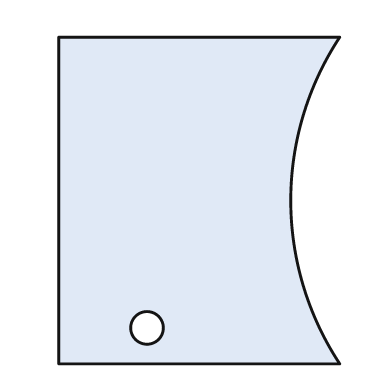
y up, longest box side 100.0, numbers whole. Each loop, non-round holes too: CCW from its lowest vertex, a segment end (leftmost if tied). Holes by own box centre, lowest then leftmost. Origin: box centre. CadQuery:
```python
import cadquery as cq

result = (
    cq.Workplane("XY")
    .moveTo(-43.0, -50.0)
    .lineTo(43.0, -50.0)
    .threePointArc((28.0, 0.0), (43.0, 50.0))
    .lineTo(-43.0, 50.0)
    .close()
    .moveTo(-16.0, -39.0)
    .circle(5.0)
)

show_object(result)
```